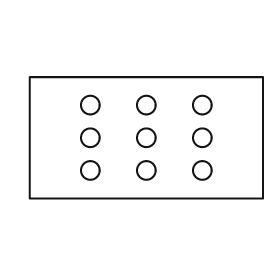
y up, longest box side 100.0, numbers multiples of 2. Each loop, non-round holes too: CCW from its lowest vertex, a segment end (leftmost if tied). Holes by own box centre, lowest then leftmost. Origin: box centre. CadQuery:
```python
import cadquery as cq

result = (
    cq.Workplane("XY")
    .moveTo(-50.0, -26.0)
    .lineTo(50.0, -26.0)
    .lineTo(50.0, 26.0)
    .lineTo(-50.0, 26.0)
    .close()
    .moveTo(-24.0, -14.0)
    .circle(4.0)
    .moveTo(0.0, -14.0)
    .circle(4.0)
    .moveTo(24.0, -14.0)
    .circle(4.0)
    .moveTo(-24.0, 0.0)
    .circle(4.0)
    .moveTo(0.0, 0.0)
    .circle(4.0)
    .moveTo(24.0, 0.0)
    .circle(4.0)
    .moveTo(-24.0, 14.0)
    .circle(4.0)
    .moveTo(0.0, 14.0)
    .circle(4.0)
    .moveTo(24.0, 14.0)
    .circle(4.0)
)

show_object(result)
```